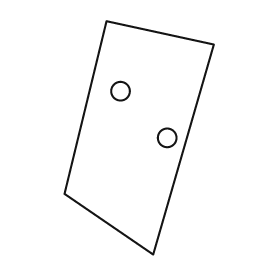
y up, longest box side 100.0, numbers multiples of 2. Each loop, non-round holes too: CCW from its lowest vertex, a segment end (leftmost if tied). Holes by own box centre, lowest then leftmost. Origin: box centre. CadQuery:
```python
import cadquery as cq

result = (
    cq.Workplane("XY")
    .moveTo(6.0, -50.0)
    .lineTo(32.0, 40.0)
    .lineTo(-14.0, 50.0)
    .lineTo(-32.0, -24.0)
    .close()
    .moveTo(12.0, 0.0)
    .circle(4.0)
    .moveTo(-8.0, 20.0)
    .circle(4.0)
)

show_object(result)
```